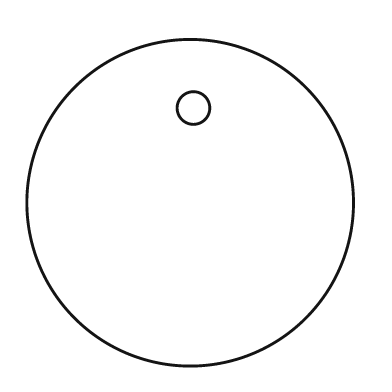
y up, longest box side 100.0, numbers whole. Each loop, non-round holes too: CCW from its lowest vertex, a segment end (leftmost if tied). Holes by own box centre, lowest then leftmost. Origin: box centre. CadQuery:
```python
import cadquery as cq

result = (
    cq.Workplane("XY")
    .moveTo(0.0, 0.0)
    .circle(50.0)
    .moveTo(1.0, 29.0)
    .circle(5.0)
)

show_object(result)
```